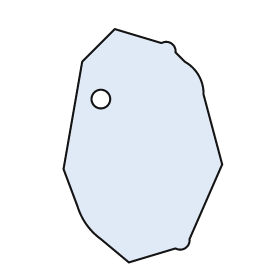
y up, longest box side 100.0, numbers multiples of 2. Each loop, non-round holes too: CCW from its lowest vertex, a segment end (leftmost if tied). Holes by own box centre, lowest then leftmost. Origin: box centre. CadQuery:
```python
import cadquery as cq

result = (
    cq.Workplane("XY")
    .moveTo(-6.0, -50.0)
    .lineTo(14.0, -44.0)
    .threePointArc((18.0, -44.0), (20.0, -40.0))
    .lineTo(34.0, -8.0)
    .lineTo(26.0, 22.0)
    .threePointArc((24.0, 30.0), (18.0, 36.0))
    .lineTo(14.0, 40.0)
    .threePointArc((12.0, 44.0), (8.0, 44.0))
    .lineTo(-12.0, 50.0)
    .lineTo(-26.0, 36.0)
    .lineTo(-34.0, -10.0)
    .lineTo(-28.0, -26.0)
    .threePointArc((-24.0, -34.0), (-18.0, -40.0))
    .close()
    .moveTo(-18.0, 20.0)
    .circle(4.0)
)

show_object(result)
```